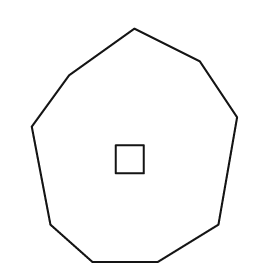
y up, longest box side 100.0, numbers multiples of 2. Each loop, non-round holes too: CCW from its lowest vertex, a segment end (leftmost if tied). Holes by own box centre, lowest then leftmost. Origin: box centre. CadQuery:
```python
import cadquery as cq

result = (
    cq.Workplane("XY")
    .moveTo(-18.0, -50.0)
    .lineTo(10.0, -50.0)
    .lineTo(36.0, -34.0)
    .lineTo(44.0, 12.0)
    .lineTo(28.0, 36.0)
    .lineTo(0.0, 50.0)
    .lineTo(-28.0, 30.0)
    .lineTo(-44.0, 8.0)
    .lineTo(-36.0, -34.0)
    .close()
    .moveTo(-8.0, -12.0)
    .lineTo(4.0, -12.0)
    .lineTo(4.0, 0.0)
    .lineTo(-8.0, 0.0)
    .close()
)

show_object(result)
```